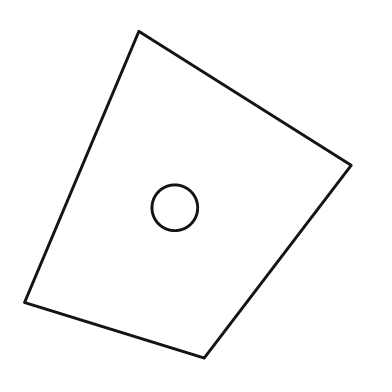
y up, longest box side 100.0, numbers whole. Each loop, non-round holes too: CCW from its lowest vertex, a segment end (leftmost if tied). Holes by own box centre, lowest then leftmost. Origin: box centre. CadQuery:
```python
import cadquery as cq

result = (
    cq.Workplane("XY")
    .moveTo(5.0, -50.0)
    .lineTo(50.0, 9.0)
    .lineTo(-15.0, 50.0)
    .lineTo(-50.0, -33.0)
    .close()
    .moveTo(-4.0, -4.0)
    .circle(7.0)
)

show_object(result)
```